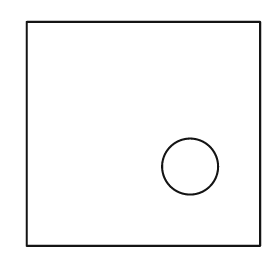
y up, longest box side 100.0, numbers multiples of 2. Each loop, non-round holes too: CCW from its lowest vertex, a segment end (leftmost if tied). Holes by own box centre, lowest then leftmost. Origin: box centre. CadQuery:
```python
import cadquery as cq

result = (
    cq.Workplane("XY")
    .moveTo(-50.0, -48.0)
    .lineTo(50.0, -48.0)
    .lineTo(50.0, 48.0)
    .lineTo(-50.0, 48.0)
    .close()
    .moveTo(20.0, -14.0)
    .circle(12.0)
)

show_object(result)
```